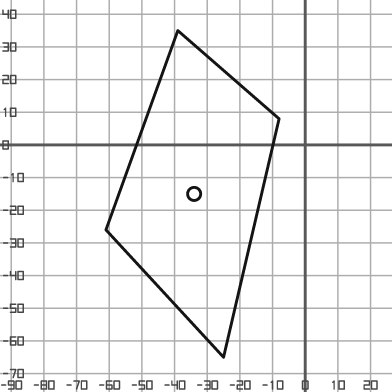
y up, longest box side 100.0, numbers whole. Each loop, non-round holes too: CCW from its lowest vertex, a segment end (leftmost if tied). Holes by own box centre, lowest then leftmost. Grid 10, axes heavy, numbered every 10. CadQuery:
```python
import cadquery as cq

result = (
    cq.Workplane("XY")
    .moveTo(-25.0, -65.0)
    .lineTo(-8.0, 8.0)
    .lineTo(-39.0, 35.0)
    .lineTo(-61.0, -26.0)
    .close()
    .moveTo(-34.0, -15.0)
    .circle(2.0)
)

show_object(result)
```